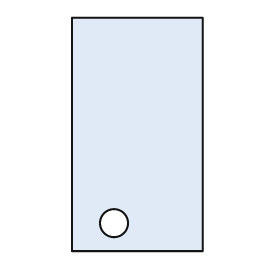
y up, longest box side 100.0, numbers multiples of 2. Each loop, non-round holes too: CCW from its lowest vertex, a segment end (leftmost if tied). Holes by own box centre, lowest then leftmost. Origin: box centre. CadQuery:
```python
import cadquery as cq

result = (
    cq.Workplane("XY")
    .moveTo(-28.0, -50.0)
    .lineTo(28.0, -50.0)
    .lineTo(28.0, 50.0)
    .lineTo(-28.0, 50.0)
    .close()
    .moveTo(-10.0, -38.0)
    .circle(6.0)
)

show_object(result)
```